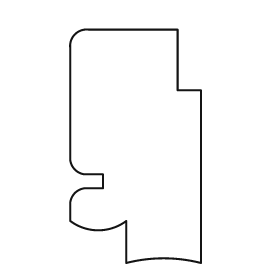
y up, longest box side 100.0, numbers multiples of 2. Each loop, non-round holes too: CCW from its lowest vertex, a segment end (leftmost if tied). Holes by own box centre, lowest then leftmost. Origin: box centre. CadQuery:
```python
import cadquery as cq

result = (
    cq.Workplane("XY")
    .moveTo(-4.0, -50.0)
    .threePointArc((12.0, -48.0), (28.0, -50.0))
    .lineTo(28.0, 24.0)
    .lineTo(18.0, 24.0)
    .lineTo(18.0, 50.0)
    .lineTo(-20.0, 50.0)
    .threePointArc((-26.0, 48.0), (-28.0, 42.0))
    .lineTo(-28.0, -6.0)
    .threePointArc((-26.0, -10.0), (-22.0, -12.0))
    .lineTo(-14.0, -12.0)
    .lineTo(-14.0, -18.0)
    .lineTo(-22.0, -18.0)
    .threePointArc((-26.0, -20.0), (-28.0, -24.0))
    .lineTo(-28.0, -32.0)
    .threePointArc((-16.0, -36.0), (-4.0, -32.0))
    .close()
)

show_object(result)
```